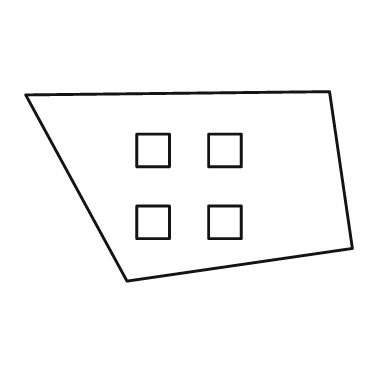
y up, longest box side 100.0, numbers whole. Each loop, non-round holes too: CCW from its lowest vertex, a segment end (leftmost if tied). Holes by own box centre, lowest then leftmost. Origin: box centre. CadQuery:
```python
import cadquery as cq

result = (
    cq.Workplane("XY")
    .moveTo(-19.0, -29.0)
    .lineTo(50.0, -19.0)
    .lineTo(43.0, 29.0)
    .lineTo(-50.0, 28.0)
    .close()
    .moveTo(-16.0, -16.0)
    .lineTo(-6.0, -16.0)
    .lineTo(-6.0, -6.0)
    .lineTo(-16.0, -6.0)
    .close()
    .moveTo(6.0, -16.0)
    .lineTo(16.0, -16.0)
    .lineTo(16.0, -6.0)
    .lineTo(6.0, -6.0)
    .close()
    .moveTo(-16.0, 6.0)
    .lineTo(-6.0, 6.0)
    .lineTo(-6.0, 16.0)
    .lineTo(-16.0, 16.0)
    .close()
    .moveTo(6.0, 6.0)
    .lineTo(16.0, 6.0)
    .lineTo(16.0, 16.0)
    .lineTo(6.0, 16.0)
    .close()
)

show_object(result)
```